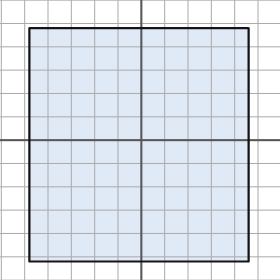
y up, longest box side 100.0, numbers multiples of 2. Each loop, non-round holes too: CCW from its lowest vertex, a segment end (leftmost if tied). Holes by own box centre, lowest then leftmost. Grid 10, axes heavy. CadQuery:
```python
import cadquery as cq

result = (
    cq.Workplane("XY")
    .moveTo(-48.0, -52.0)
    .lineTo(46.0, -52.0)
    .lineTo(46.0, 48.0)
    .lineTo(-48.0, 48.0)
    .close()
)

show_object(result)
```